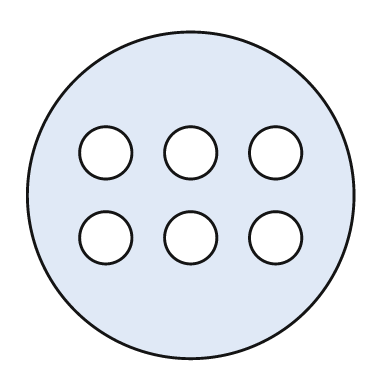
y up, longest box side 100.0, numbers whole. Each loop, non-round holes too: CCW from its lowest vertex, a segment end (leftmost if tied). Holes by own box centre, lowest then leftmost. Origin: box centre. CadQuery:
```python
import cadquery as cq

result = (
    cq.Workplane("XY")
    .moveTo(0.0, 0.0)
    .circle(50.0)
    .moveTo(-26.0, -13.0)
    .circle(8.0)
    .moveTo(0.0, -13.0)
    .circle(8.0)
    .moveTo(26.0, -13.0)
    .circle(8.0)
    .moveTo(-26.0, 13.0)
    .circle(8.0)
    .moveTo(0.0, 13.0)
    .circle(8.0)
    .moveTo(26.0, 13.0)
    .circle(8.0)
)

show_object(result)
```